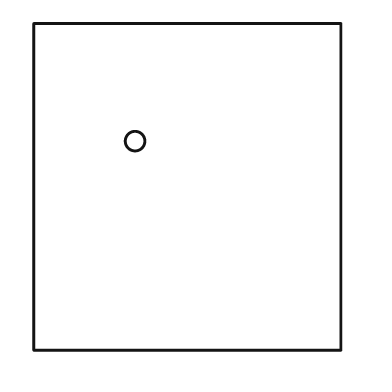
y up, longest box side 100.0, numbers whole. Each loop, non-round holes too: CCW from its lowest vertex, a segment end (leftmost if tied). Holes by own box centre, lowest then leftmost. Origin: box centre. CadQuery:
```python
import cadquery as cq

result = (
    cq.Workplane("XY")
    .moveTo(-47.0, -50.0)
    .lineTo(47.0, -50.0)
    .lineTo(47.0, 50.0)
    .lineTo(-47.0, 50.0)
    .close()
    .moveTo(-16.0, 14.0)
    .circle(3.0)
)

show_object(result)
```